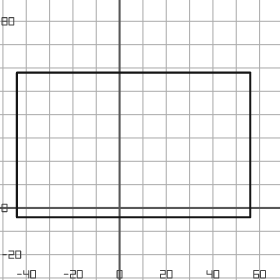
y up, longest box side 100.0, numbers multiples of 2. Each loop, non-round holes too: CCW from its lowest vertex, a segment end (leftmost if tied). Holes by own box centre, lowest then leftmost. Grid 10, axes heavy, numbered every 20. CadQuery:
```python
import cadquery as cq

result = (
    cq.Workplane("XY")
    .moveTo(-44.0, -4.0)
    .lineTo(56.0, -4.0)
    .lineTo(56.0, 58.0)
    .lineTo(-44.0, 58.0)
    .close()
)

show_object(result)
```